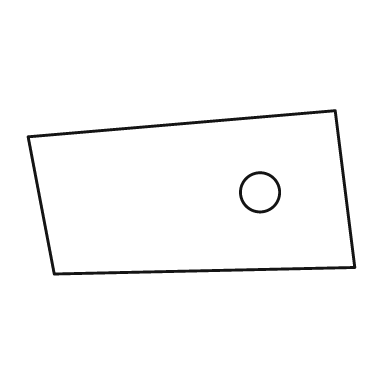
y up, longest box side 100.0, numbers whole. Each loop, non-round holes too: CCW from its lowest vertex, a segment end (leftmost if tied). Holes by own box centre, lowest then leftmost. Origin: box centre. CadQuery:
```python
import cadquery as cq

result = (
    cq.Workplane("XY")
    .moveTo(-42.0, -25.0)
    .lineTo(50.0, -23.0)
    .lineTo(44.0, 25.0)
    .lineTo(-50.0, 17.0)
    .close()
    .moveTo(21.0, 0.0)
    .circle(6.0)
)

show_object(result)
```